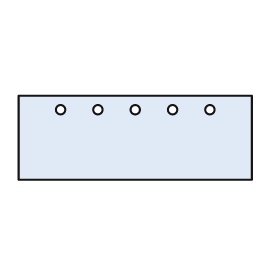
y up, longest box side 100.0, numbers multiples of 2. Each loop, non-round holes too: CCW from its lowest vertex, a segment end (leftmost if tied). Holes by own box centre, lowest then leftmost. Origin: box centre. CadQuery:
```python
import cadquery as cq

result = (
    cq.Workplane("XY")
    .moveTo(-50.0, -18.0)
    .lineTo(50.0, -18.0)
    .lineTo(50.0, 18.0)
    .lineTo(-50.0, 18.0)
    .close()
    .moveTo(-32.0, 12.0)
    .circle(2.0)
    .moveTo(-16.0, 12.0)
    .circle(2.0)
    .moveTo(0.0, 12.0)
    .circle(2.0)
    .moveTo(16.0, 12.0)
    .circle(2.0)
    .moveTo(32.0, 12.0)
    .circle(2.0)
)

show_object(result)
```